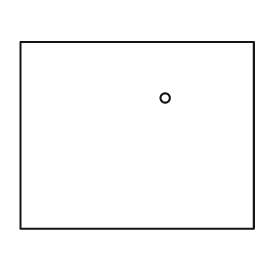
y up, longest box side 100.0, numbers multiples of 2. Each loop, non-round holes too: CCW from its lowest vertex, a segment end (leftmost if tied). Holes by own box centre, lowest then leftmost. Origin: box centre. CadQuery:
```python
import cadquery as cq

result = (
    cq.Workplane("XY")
    .moveTo(-50.0, -40.0)
    .lineTo(50.0, -40.0)
    .lineTo(50.0, 40.0)
    .lineTo(-50.0, 40.0)
    .close()
    .moveTo(12.0, 16.0)
    .circle(2.0)
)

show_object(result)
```